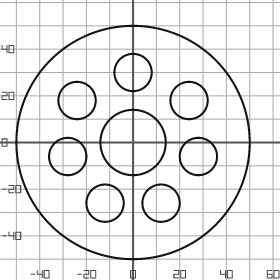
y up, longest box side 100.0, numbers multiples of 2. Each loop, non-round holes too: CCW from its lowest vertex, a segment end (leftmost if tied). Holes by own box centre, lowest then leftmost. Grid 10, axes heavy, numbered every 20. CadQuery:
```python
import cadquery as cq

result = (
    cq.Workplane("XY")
    .moveTo(0.0, 0.0)
    .circle(50.0)
    .moveTo(-12.0, -26.0)
    .circle(8.0)
    .moveTo(12.0, -26.0)
    .circle(8.0)
    .moveTo(-28.0, -6.0)
    .circle(8.0)
    .moveTo(28.0, -6.0)
    .circle(8.0)
    .moveTo(0.0, 0.0)
    .circle(14.0)
    .moveTo(-24.0, 18.0)
    .circle(8.0)
    .moveTo(24.0, 18.0)
    .circle(8.0)
    .moveTo(0.0, 30.0)
    .circle(8.0)
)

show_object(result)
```